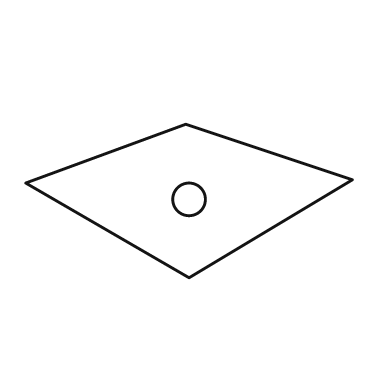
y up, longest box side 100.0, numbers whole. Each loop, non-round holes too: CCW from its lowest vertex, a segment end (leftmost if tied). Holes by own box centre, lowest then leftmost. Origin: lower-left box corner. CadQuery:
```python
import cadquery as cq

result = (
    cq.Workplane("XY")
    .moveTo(50.0, 0.0)
    .lineTo(100.0, 30.0)
    .lineTo(49.0, 47.0)
    .lineTo(0.0, 29.0)
    .close()
    .moveTo(50.0, 24.0)
    .circle(5.0)
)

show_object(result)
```